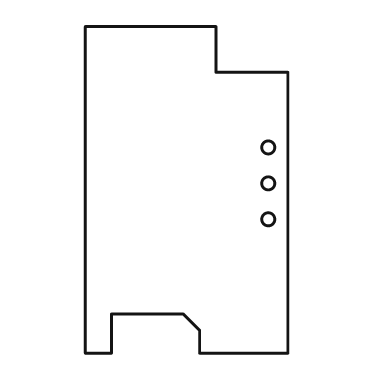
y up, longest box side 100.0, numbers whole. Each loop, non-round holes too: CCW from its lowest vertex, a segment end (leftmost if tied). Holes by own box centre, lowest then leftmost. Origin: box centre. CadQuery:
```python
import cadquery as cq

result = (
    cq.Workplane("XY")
    .moveTo(-31.0, -50.0)
    .lineTo(-23.0, -50.0)
    .lineTo(-23.0, -38.0)
    .lineTo(-1.0, -38.0)
    .lineTo(4.0, -43.0)
    .lineTo(4.0, -50.0)
    .lineTo(31.0, -50.0)
    .lineTo(31.0, 36.0)
    .lineTo(9.0, 36.0)
    .lineTo(9.0, 50.0)
    .lineTo(-31.0, 50.0)
    .close()
    .moveTo(25.0, -9.0)
    .circle(2.0)
    .moveTo(25.0, 2.0)
    .circle(2.0)
    .moveTo(25.0, 13.0)
    .circle(2.0)
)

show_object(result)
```